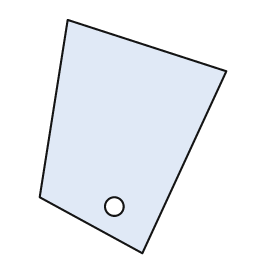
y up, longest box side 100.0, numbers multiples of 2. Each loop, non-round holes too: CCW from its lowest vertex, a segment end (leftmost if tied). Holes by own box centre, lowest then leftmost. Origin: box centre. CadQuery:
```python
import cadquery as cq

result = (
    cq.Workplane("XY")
    .moveTo(4.0, -50.0)
    .lineTo(40.0, 28.0)
    .lineTo(-28.0, 50.0)
    .lineTo(-40.0, -26.0)
    .close()
    .moveTo(-8.0, -30.0)
    .circle(4.0)
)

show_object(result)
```